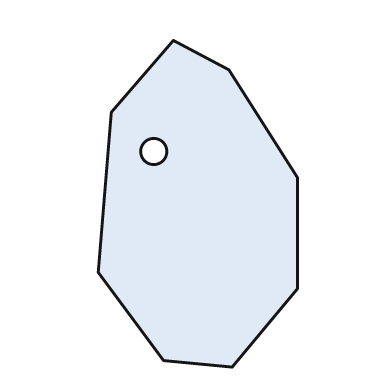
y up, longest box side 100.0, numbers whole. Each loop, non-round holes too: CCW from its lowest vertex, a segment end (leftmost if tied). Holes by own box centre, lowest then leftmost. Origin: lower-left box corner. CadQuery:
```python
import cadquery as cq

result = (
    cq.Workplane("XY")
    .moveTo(41.0, 0.0)
    .lineTo(61.0, 24.0)
    .lineTo(61.0, 58.0)
    .lineTo(40.0, 91.0)
    .lineTo(23.0, 100.0)
    .lineTo(4.0, 78.0)
    .lineTo(0.0, 29.0)
    .lineTo(20.0, 2.0)
    .close()
    .moveTo(17.0, 66.0)
    .circle(4.0)
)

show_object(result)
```